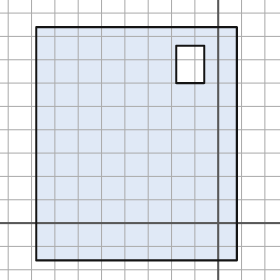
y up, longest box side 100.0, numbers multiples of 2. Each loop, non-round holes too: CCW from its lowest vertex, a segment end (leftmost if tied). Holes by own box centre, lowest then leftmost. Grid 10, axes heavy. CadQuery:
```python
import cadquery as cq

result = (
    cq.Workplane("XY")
    .moveTo(-78.0, -16.0)
    .lineTo(8.0, -16.0)
    .lineTo(8.0, 84.0)
    .lineTo(-78.0, 84.0)
    .close()
    .moveTo(-18.0, 60.0)
    .lineTo(-6.0, 60.0)
    .lineTo(-6.0, 76.0)
    .lineTo(-18.0, 76.0)
    .close()
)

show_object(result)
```